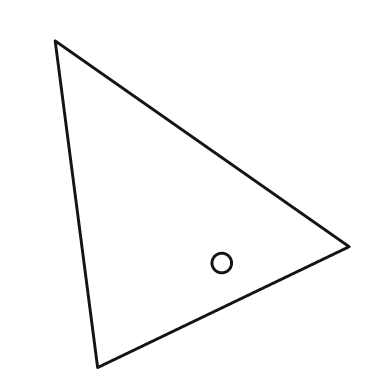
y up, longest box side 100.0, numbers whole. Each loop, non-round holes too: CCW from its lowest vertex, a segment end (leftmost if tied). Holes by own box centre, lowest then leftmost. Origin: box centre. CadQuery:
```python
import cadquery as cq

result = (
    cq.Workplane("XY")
    .moveTo(-32.0, -50.0)
    .lineTo(45.0, -13.0)
    .lineTo(-45.0, 50.0)
    .close()
    .moveTo(6.0, -18.0)
    .circle(3.0)
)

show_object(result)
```